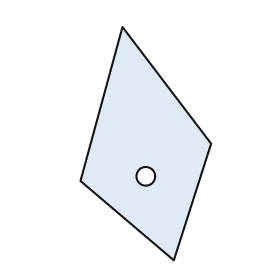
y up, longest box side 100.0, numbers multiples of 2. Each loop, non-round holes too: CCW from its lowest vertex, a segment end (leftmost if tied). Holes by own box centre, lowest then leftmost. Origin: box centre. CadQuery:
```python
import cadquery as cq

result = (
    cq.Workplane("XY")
    .moveTo(12.0, -50.0)
    .lineTo(28.0, 0.0)
    .lineTo(-10.0, 50.0)
    .lineTo(-28.0, -16.0)
    .close()
    .moveTo(0.0, -14.0)
    .circle(4.0)
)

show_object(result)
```